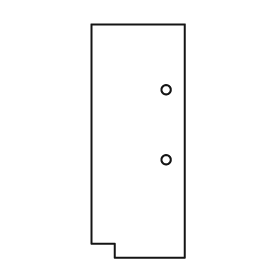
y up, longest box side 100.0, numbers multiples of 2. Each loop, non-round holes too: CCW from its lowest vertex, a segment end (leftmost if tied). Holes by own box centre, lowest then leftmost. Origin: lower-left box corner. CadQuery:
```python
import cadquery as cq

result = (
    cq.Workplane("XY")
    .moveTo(10.0, 0.0)
    .lineTo(40.0, 0.0)
    .lineTo(40.0, 100.0)
    .lineTo(0.0, 100.0)
    .lineTo(0.0, 6.0)
    .lineTo(10.0, 6.0)
    .close()
    .moveTo(32.0, 42.0)
    .circle(2.0)
    .moveTo(32.0, 72.0)
    .circle(2.0)
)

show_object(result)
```